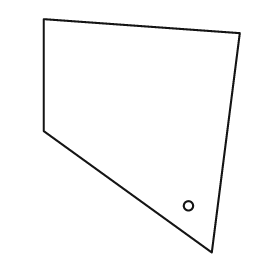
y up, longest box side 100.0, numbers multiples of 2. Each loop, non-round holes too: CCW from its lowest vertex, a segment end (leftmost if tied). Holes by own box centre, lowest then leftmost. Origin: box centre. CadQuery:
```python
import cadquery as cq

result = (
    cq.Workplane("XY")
    .moveTo(30.0, -50.0)
    .lineTo(42.0, 44.0)
    .lineTo(-42.0, 50.0)
    .lineTo(-42.0, 2.0)
    .close()
    .moveTo(20.0, -30.0)
    .circle(2.0)
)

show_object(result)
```